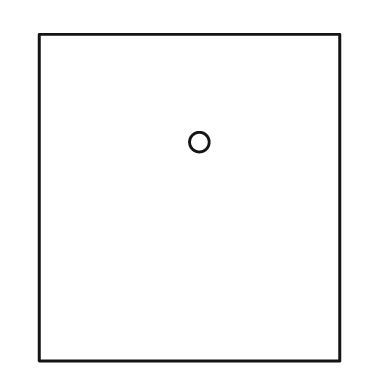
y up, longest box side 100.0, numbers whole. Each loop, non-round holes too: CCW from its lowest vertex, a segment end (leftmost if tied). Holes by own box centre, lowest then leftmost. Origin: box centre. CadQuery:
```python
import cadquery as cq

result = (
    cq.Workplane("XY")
    .moveTo(-46.0, -50.0)
    .lineTo(46.0, -50.0)
    .lineTo(46.0, 50.0)
    .lineTo(-46.0, 50.0)
    .close()
    .moveTo(3.0, 17.0)
    .circle(3.0)
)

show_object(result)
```